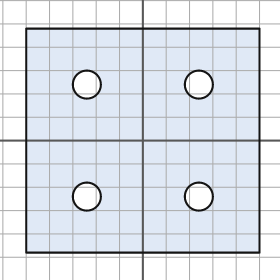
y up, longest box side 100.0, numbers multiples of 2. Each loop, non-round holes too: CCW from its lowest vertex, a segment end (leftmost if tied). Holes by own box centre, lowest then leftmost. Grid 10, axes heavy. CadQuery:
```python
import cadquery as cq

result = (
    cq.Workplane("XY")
    .moveTo(-50.0, -48.0)
    .lineTo(50.0, -48.0)
    .lineTo(50.0, 48.0)
    .lineTo(-50.0, 48.0)
    .close()
    .moveTo(-24.0, -24.0)
    .circle(6.0)
    .moveTo(24.0, -24.0)
    .circle(6.0)
    .moveTo(-24.0, 24.0)
    .circle(6.0)
    .moveTo(24.0, 24.0)
    .circle(6.0)
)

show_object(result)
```